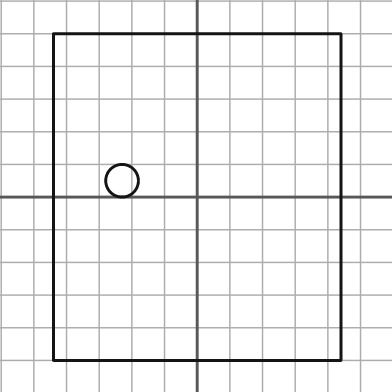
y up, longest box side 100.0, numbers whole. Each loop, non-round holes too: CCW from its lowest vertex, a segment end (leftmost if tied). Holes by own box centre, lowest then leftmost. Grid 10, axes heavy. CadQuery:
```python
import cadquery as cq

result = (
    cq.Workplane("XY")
    .moveTo(-44.0, -50.0)
    .lineTo(44.0, -50.0)
    .lineTo(44.0, 50.0)
    .lineTo(-44.0, 50.0)
    .close()
    .moveTo(-23.0, 5.0)
    .circle(5.0)
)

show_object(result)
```